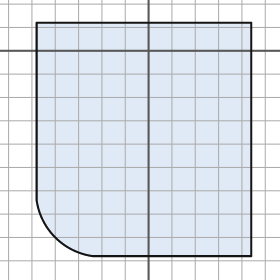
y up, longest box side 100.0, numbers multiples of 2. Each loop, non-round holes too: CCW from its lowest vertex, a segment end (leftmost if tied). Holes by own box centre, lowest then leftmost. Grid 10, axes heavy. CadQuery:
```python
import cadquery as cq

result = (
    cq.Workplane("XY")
    .moveTo(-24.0, -88.0)
    .lineTo(44.0, -88.0)
    .lineTo(44.0, 12.0)
    .lineTo(-48.0, 12.0)
    .lineTo(-48.0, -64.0)
    .threePointArc((-40.0, -80.0), (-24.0, -88.0))
    .close()
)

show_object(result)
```